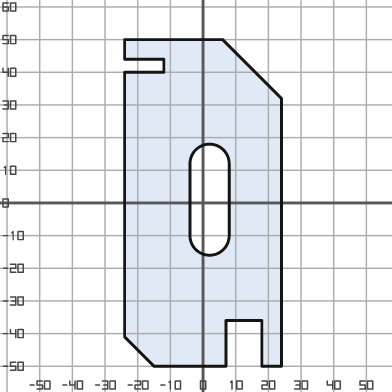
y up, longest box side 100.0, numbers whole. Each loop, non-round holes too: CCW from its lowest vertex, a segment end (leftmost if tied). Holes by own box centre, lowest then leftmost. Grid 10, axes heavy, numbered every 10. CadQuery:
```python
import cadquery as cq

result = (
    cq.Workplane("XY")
    .moveTo(-15.0, -50.0)
    .lineTo(7.0, -50.0)
    .lineTo(7.0, -36.0)
    .lineTo(18.0, -36.0)
    .lineTo(18.0, -50.0)
    .lineTo(24.0, -50.0)
    .lineTo(24.0, 32.0)
    .lineTo(6.0, 50.0)
    .lineTo(-24.0, 50.0)
    .lineTo(-24.0, 44.0)
    .lineTo(-12.0, 44.0)
    .lineTo(-12.0, 40.0)
    .lineTo(-24.0, 40.0)
    .lineTo(-24.0, -41.0)
    .close()
    .moveTo(-4.0, -10.0)
    .threePointArc((2.0, -16.0), (8.0, -10.0))
    .lineTo(8.0, 12.0)
    .threePointArc((2.0, 18.0), (-4.0, 12.0))
    .close()
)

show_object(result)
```